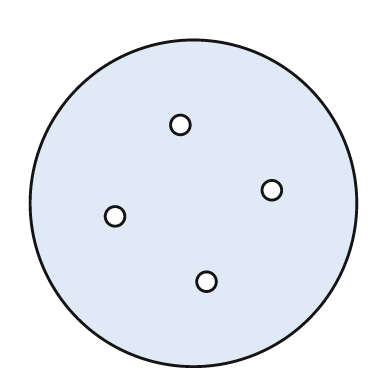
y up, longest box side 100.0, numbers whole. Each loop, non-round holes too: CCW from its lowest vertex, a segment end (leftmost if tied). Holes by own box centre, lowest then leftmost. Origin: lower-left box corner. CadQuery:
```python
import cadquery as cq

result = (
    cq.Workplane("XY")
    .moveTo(50.0, 50.0)
    .circle(50.0)
    .moveTo(54.0, 26.0)
    .circle(3.0)
    .moveTo(26.0, 46.0)
    .circle(3.0)
    .moveTo(74.0, 54.0)
    .circle(3.0)
    .moveTo(46.0, 74.0)
    .circle(3.0)
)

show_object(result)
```